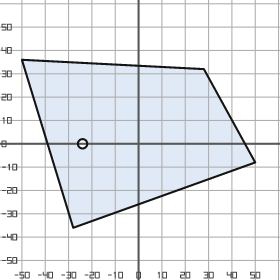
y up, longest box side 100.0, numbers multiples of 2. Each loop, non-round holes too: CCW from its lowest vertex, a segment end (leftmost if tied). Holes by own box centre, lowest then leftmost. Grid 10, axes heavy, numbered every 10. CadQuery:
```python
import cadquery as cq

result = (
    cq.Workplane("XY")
    .moveTo(-28.0, -36.0)
    .lineTo(50.0, -8.0)
    .lineTo(28.0, 32.0)
    .lineTo(-50.0, 36.0)
    .close()
    .moveTo(-24.0, 0.0)
    .circle(2.0)
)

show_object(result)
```